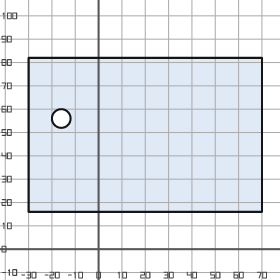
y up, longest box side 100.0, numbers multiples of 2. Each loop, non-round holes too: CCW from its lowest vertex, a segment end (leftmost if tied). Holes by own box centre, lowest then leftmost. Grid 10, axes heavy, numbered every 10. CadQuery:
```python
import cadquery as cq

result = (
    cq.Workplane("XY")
    .moveTo(-30.0, 16.0)
    .lineTo(70.0, 16.0)
    .lineTo(70.0, 82.0)
    .lineTo(-30.0, 82.0)
    .close()
    .moveTo(-16.0, 56.0)
    .circle(4.0)
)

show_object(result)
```